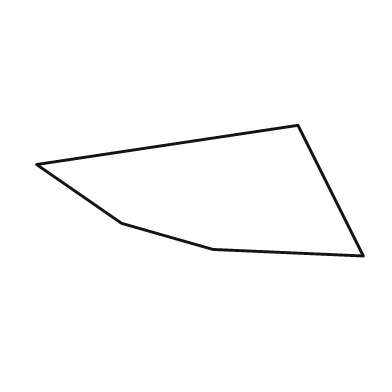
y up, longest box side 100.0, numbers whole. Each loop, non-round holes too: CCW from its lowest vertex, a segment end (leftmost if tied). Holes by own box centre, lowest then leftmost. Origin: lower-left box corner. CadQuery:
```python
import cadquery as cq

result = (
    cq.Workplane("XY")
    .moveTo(100.0, 0.0)
    .lineTo(80.0, 40.0)
    .lineTo(0.0, 28.0)
    .lineTo(26.0, 10.0)
    .lineTo(54.0, 2.0)
    .close()
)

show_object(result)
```